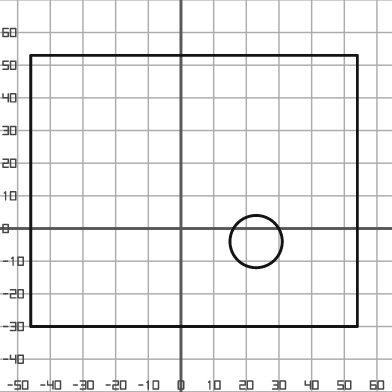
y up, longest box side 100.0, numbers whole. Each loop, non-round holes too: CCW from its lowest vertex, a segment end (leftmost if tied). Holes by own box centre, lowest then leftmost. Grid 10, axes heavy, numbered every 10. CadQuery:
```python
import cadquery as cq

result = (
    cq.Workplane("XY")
    .moveTo(-46.0, -30.0)
    .lineTo(54.0, -30.0)
    .lineTo(54.0, 53.0)
    .lineTo(-46.0, 53.0)
    .close()
    .moveTo(23.0, -4.0)
    .circle(8.0)
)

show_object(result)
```